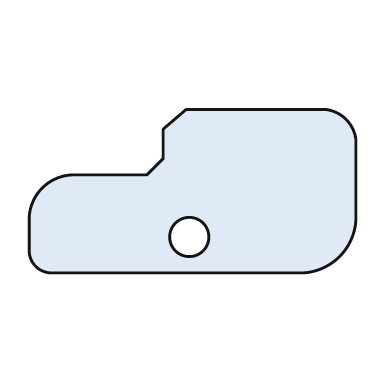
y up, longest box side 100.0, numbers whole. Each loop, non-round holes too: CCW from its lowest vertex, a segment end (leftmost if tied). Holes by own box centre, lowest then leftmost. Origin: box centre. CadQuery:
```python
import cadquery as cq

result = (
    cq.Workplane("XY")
    .moveTo(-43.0, -25.0)
    .lineTo(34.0, -25.0)
    .threePointArc((45.0, -20.0), (50.0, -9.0))
    .lineTo(50.0, 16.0)
    .threePointArc((47.0, 22.0), (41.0, 25.0))
    .lineTo(-2.0, 25.0)
    .lineTo(-9.0, 19.0)
    .lineTo(-9.0, 10.0)
    .lineTo(-14.0, 5.0)
    .lineTo(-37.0, 5.0)
    .threePointArc((-46.0, 1.0), (-50.0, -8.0))
    .lineTo(-50.0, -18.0)
    .threePointArc((-48.0, -23.0), (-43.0, -25.0))
    .close()
    .moveTo(-1.0, -14.0)
    .circle(6.0)
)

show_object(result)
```